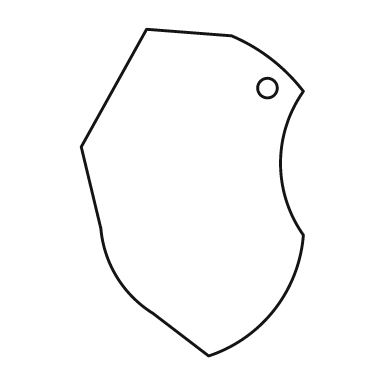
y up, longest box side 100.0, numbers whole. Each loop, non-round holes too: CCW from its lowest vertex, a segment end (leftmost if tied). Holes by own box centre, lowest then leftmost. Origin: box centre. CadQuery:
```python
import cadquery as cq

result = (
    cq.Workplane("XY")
    .moveTo(5.0, -50.0)
    .threePointArc((25.0, -36.0), (34.0, -13.0))
    .threePointArc((27.0, 9.0), (34.0, 31.0))
    .threePointArc((24.0, 41.0), (12.0, 48.0))
    .lineTo(-14.0, 50.0)
    .lineTo(-34.0, 14.0)
    .lineTo(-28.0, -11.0)
    .threePointArc((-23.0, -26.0), (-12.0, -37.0))
    .close()
    .moveTo(23.0, 32.0)
    .circle(3.0)
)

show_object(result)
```